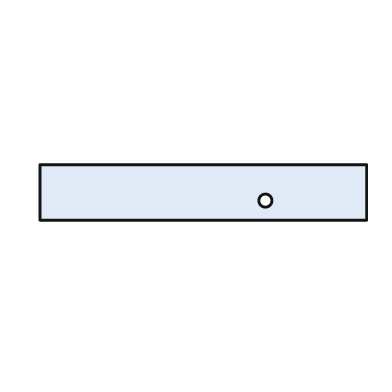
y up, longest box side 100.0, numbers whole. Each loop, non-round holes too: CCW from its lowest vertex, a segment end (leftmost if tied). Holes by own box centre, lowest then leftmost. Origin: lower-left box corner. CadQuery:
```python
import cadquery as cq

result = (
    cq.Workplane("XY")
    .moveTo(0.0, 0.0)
    .lineTo(100.0, 0.0)
    .lineTo(100.0, 17.0)
    .lineTo(0.0, 17.0)
    .close()
    .moveTo(69.0, 6.0)
    .circle(2.0)
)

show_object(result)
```